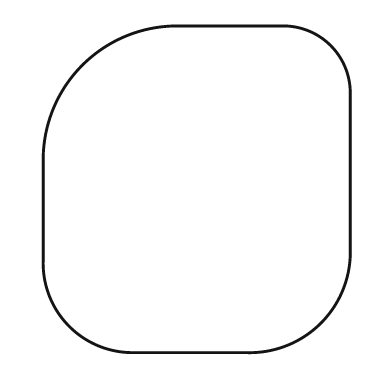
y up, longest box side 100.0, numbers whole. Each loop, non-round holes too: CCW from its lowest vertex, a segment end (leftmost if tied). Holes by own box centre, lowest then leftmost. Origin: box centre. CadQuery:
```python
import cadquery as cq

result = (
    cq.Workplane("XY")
    .moveTo(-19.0, -50.0)
    .lineTo(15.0, -50.0)
    .threePointArc((38.0, -41.0), (47.0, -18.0))
    .lineTo(47.0, 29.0)
    .threePointArc((41.0, 44.0), (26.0, 50.0))
    .lineTo(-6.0, 50.0)
    .threePointArc((-35.0, 38.0), (-47.0, 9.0))
    .lineTo(-47.0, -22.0)
    .threePointArc((-39.0, -42.0), (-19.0, -50.0))
    .close()
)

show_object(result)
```